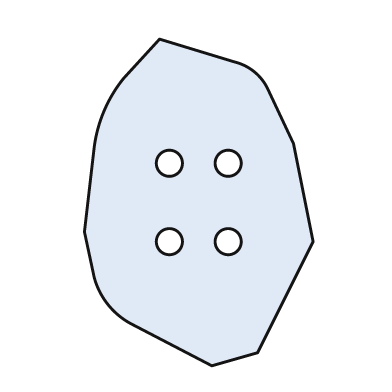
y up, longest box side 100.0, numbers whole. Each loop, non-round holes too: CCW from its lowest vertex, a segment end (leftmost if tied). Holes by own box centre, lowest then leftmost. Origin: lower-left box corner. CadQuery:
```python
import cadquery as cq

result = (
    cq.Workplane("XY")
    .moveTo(39.0, 0.0)
    .lineTo(53.0, 4.0)
    .lineTo(70.0, 38.0)
    .lineTo(64.0, 68.0)
    .lineTo(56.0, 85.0)
    .threePointArc((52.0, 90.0), (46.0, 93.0))
    .lineTo(23.0, 100.0)
    .lineTo(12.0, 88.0)
    .threePointArc((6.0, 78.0), (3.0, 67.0))
    .lineTo(0.0, 41.0)
    .lineTo(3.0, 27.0)
    .threePointArc((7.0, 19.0), (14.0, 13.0))
    .close()
    .moveTo(26.0, 38.0)
    .circle(4.0)
    .moveTo(44.0, 38.0)
    .circle(4.0)
    .moveTo(26.0, 62.0)
    .circle(4.0)
    .moveTo(44.0, 62.0)
    .circle(4.0)
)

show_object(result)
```